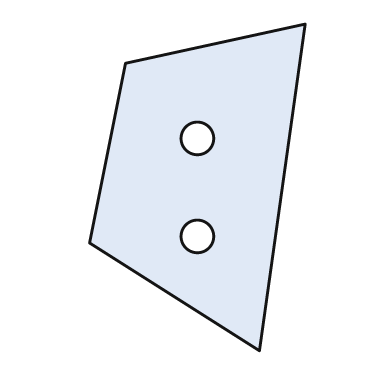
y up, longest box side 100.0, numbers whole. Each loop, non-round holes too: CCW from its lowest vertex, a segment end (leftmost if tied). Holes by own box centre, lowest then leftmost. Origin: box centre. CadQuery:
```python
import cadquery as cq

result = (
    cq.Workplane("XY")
    .moveTo(19.0, -50.0)
    .lineTo(33.0, 50.0)
    .lineTo(-22.0, 38.0)
    .lineTo(-33.0, -17.0)
    .close()
    .moveTo(0.0, -15.0)
    .circle(5.0)
    .moveTo(0.0, 15.0)
    .circle(5.0)
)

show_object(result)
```